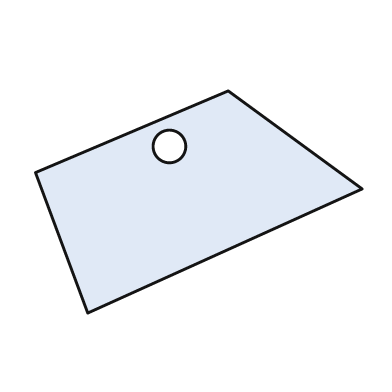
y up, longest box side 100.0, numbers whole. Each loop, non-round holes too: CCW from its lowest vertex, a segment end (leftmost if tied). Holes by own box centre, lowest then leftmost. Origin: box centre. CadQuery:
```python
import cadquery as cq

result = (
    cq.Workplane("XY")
    .moveTo(-34.0, -34.0)
    .lineTo(50.0, 4.0)
    .lineTo(9.0, 34.0)
    .lineTo(-50.0, 9.0)
    .close()
    .moveTo(-9.0, 17.0)
    .circle(5.0)
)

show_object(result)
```